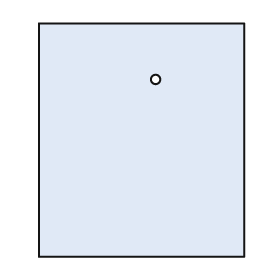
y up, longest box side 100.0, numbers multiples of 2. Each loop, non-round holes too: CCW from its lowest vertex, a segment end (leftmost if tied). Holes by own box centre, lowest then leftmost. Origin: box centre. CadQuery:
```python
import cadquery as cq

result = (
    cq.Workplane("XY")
    .moveTo(-44.0, -50.0)
    .lineTo(44.0, -50.0)
    .lineTo(44.0, 50.0)
    .lineTo(-44.0, 50.0)
    .close()
    .moveTo(6.0, 26.0)
    .circle(2.0)
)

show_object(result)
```